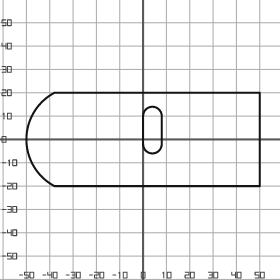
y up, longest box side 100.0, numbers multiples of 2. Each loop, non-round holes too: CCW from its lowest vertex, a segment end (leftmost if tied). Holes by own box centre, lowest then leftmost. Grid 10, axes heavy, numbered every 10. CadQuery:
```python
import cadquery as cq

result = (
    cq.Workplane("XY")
    .moveTo(-38.0, -20.0)
    .lineTo(50.0, -20.0)
    .lineTo(50.0, 20.0)
    .lineTo(-38.0, 20.0)
    .threePointArc((-50.0, 0.0), (-38.0, -20.0))
    .close()
    .moveTo(0.0, -2.0)
    .threePointArc((4.0, -6.0), (8.0, -2.0))
    .lineTo(8.0, 10.0)
    .threePointArc((4.0, 14.0), (0.0, 10.0))
    .close()
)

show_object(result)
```